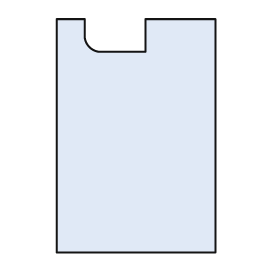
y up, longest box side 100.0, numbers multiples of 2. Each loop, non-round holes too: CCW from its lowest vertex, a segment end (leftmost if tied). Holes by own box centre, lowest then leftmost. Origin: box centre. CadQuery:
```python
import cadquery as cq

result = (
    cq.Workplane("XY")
    .moveTo(-34.0, -50.0)
    .lineTo(34.0, -50.0)
    .lineTo(34.0, 50.0)
    .lineTo(4.0, 50.0)
    .lineTo(4.0, 36.0)
    .lineTo(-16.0, 36.0)
    .threePointArc((-20.0, 38.0), (-22.0, 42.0))
    .lineTo(-22.0, 50.0)
    .lineTo(-34.0, 50.0)
    .close()
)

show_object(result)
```